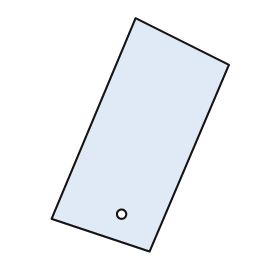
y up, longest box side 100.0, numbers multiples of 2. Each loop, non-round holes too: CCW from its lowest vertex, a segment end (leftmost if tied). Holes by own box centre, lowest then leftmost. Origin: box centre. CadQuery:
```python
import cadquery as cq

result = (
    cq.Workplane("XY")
    .moveTo(4.0, -50.0)
    .lineTo(38.0, 30.0)
    .lineTo(-2.0, 50.0)
    .lineTo(-38.0, -36.0)
    .close()
    .moveTo(-8.0, -34.0)
    .circle(2.0)
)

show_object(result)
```